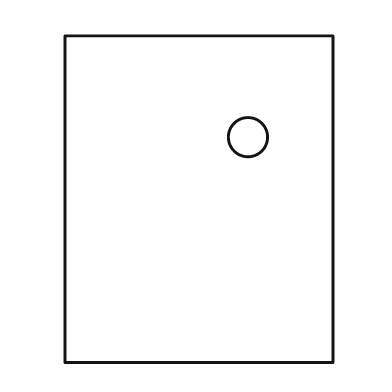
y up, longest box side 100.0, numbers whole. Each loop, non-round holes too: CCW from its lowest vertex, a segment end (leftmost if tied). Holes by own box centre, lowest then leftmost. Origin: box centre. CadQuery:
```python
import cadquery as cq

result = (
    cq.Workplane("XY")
    .moveTo(-41.0, -50.0)
    .lineTo(41.0, -50.0)
    .lineTo(41.0, 50.0)
    .lineTo(-41.0, 50.0)
    .close()
    .moveTo(15.0, 19.0)
    .circle(6.0)
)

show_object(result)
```